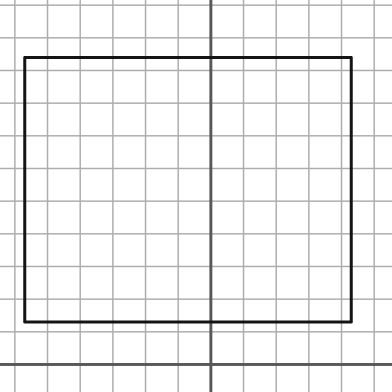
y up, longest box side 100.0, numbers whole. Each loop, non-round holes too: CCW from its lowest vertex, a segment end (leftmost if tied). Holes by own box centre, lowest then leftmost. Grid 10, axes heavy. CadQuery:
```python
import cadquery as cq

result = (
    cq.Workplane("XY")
    .moveTo(-57.0, 13.0)
    .lineTo(43.0, 13.0)
    .lineTo(43.0, 94.0)
    .lineTo(-57.0, 94.0)
    .close()
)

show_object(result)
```